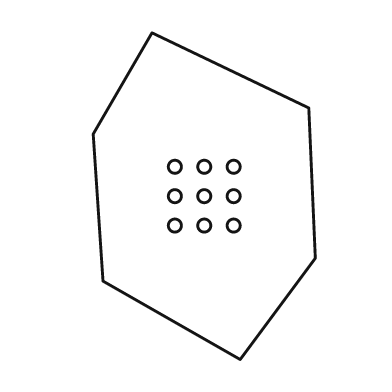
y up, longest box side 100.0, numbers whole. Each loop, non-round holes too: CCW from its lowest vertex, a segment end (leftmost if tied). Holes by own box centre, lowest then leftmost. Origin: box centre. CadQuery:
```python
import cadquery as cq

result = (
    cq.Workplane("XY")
    .moveTo(11.0, -50.0)
    .lineTo(34.0, -19.0)
    .lineTo(32.0, 27.0)
    .lineTo(-16.0, 50.0)
    .lineTo(-34.0, 19.0)
    .lineTo(-31.0, -26.0)
    .close()
    .moveTo(-9.0, -9.0)
    .circle(2.0)
    .moveTo(0.0, -9.0)
    .circle(2.0)
    .moveTo(9.0, -9.0)
    .circle(2.0)
    .moveTo(-9.0, 0.0)
    .circle(2.0)
    .moveTo(0.0, 0.0)
    .circle(2.0)
    .moveTo(9.0, 0.0)
    .circle(2.0)
    .moveTo(-9.0, 9.0)
    .circle(2.0)
    .moveTo(0.0, 9.0)
    .circle(2.0)
    .moveTo(9.0, 9.0)
    .circle(2.0)
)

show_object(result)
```